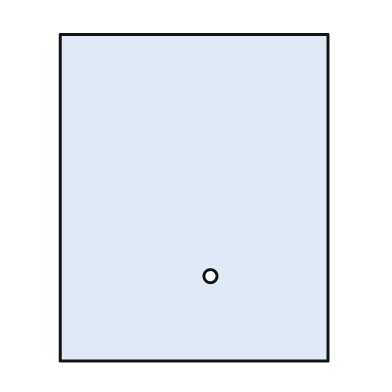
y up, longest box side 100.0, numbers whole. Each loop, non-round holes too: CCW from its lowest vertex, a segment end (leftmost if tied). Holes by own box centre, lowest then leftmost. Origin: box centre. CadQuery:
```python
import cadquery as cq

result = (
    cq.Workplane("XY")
    .moveTo(-41.0, -50.0)
    .lineTo(41.0, -50.0)
    .lineTo(41.0, 50.0)
    .lineTo(-41.0, 50.0)
    .close()
    .moveTo(5.0, -24.0)
    .circle(2.0)
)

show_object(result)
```